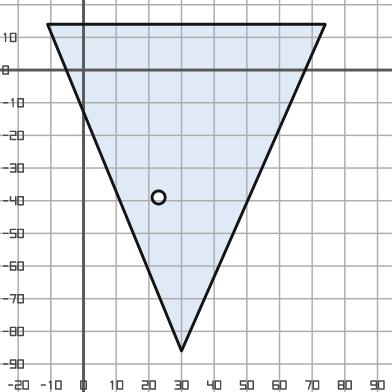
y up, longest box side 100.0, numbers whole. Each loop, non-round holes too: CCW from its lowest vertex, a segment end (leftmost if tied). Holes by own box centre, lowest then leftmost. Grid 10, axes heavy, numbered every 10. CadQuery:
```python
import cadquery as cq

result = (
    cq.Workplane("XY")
    .moveTo(30.0, -86.0)
    .lineTo(74.0, 14.0)
    .lineTo(-11.0, 14.0)
    .close()
    .moveTo(23.0, -39.0)
    .circle(2.0)
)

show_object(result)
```